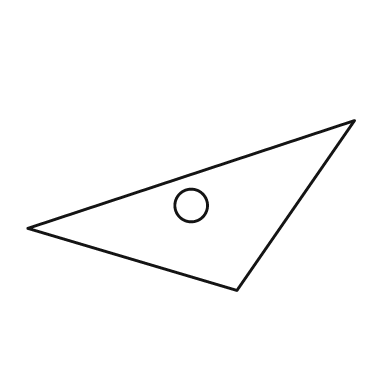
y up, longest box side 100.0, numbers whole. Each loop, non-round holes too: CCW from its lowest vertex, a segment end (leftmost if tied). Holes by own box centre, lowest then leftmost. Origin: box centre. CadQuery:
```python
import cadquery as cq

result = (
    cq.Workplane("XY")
    .moveTo(14.0, -26.0)
    .lineTo(50.0, 26.0)
    .lineTo(-50.0, -7.0)
    .close()
    .moveTo(0.0, 0.0)
    .circle(5.0)
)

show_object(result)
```